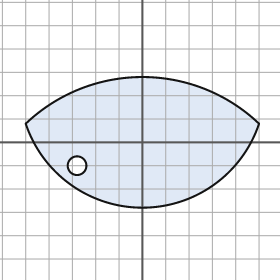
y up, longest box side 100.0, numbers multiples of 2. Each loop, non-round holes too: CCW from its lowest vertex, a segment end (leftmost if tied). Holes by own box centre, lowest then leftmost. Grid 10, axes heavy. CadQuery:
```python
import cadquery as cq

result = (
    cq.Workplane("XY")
    .moveTo(-50.0, 8.0)
    .threePointArc((0.0, -28.0), (50.0, 8.0))
    .threePointArc((0.0, 28.0), (-50.0, 8.0))
    .close()
    .moveTo(-28.0, -10.0)
    .circle(4.0)
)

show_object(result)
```